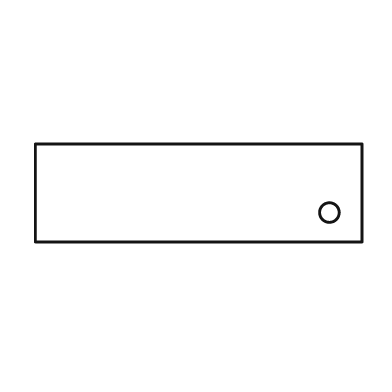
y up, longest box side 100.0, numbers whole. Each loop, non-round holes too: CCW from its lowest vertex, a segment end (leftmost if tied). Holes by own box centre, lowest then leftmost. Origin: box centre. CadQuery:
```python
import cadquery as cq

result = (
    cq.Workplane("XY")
    .moveTo(-50.0, -15.0)
    .lineTo(50.0, -15.0)
    .lineTo(50.0, 15.0)
    .lineTo(-50.0, 15.0)
    .close()
    .moveTo(40.0, -6.0)
    .circle(3.0)
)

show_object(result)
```